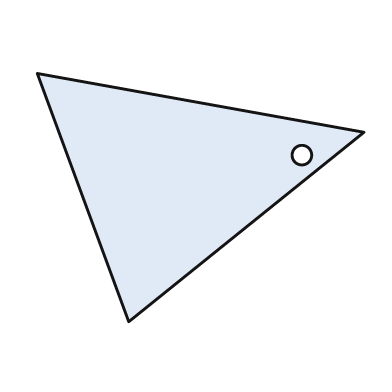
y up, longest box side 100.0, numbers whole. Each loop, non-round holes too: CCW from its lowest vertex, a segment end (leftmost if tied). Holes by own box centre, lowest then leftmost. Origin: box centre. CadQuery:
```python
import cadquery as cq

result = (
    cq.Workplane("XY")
    .moveTo(-22.0, -38.0)
    .lineTo(50.0, 20.0)
    .lineTo(-50.0, 38.0)
    .close()
    .moveTo(31.0, 13.0)
    .circle(3.0)
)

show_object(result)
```